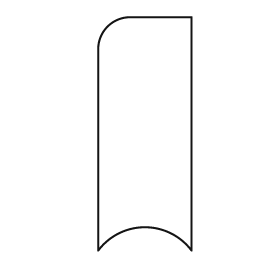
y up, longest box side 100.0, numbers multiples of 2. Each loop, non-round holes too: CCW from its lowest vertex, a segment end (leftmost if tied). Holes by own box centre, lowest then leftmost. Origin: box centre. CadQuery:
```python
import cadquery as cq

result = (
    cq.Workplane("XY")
    .moveTo(-20.0, -50.0)
    .threePointArc((0.0, -40.0), (20.0, -50.0))
    .lineTo(20.0, 50.0)
    .lineTo(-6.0, 50.0)
    .threePointArc((-16.0, 46.0), (-20.0, 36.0))
    .close()
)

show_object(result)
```